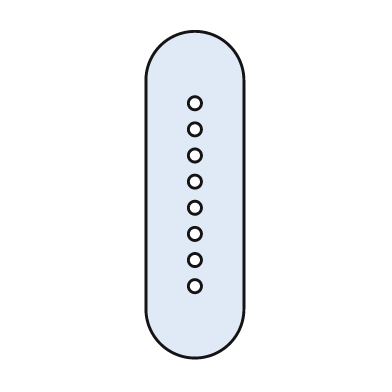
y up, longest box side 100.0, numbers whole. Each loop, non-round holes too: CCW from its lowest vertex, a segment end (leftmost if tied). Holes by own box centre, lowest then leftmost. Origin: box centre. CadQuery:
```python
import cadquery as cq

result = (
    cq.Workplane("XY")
    .moveTo(-15.0, -35.0)
    .threePointArc((0.0, -50.0), (15.0, -35.0))
    .lineTo(15.0, 35.0)
    .threePointArc((0.0, 50.0), (-15.0, 35.0))
    .close()
    .moveTo(0.0, -28.0)
    .circle(2.0)
    .moveTo(0.0, -20.0)
    .circle(2.0)
    .moveTo(0.0, -12.0)
    .circle(2.0)
    .moveTo(0.0, -4.0)
    .circle(2.0)
    .moveTo(0.0, 4.0)
    .circle(2.0)
    .moveTo(0.0, 12.0)
    .circle(2.0)
    .moveTo(0.0, 20.0)
    .circle(2.0)
    .moveTo(0.0, 28.0)
    .circle(2.0)
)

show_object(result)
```